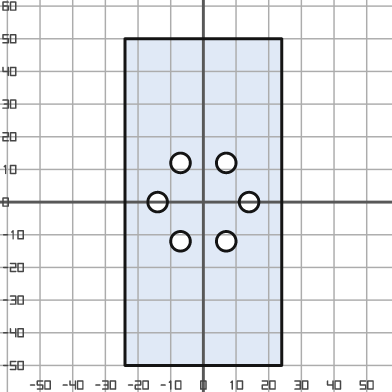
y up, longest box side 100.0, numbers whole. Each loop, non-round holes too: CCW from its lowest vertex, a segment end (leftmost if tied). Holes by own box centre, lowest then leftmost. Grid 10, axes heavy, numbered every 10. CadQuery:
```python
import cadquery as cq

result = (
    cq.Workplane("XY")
    .moveTo(-24.0, -50.0)
    .lineTo(24.0, -50.0)
    .lineTo(24.0, 50.0)
    .lineTo(-24.0, 50.0)
    .close()
    .moveTo(-7.0, -12.0)
    .circle(3.0)
    .moveTo(7.0, -12.0)
    .circle(3.0)
    .moveTo(-14.0, 0.0)
    .circle(3.0)
    .moveTo(14.0, 0.0)
    .circle(3.0)
    .moveTo(-7.0, 12.0)
    .circle(3.0)
    .moveTo(7.0, 12.0)
    .circle(3.0)
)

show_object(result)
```